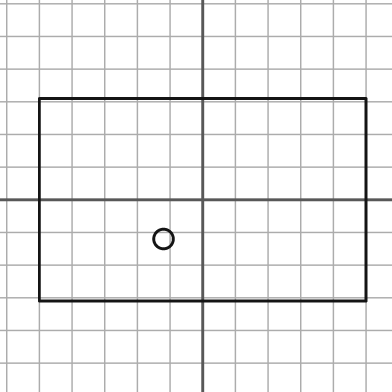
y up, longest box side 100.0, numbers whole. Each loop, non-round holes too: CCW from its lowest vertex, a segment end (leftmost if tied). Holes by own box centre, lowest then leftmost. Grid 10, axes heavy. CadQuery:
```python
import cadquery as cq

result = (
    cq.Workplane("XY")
    .moveTo(-50.0, -31.0)
    .lineTo(50.0, -31.0)
    .lineTo(50.0, 31.0)
    .lineTo(-50.0, 31.0)
    .close()
    .moveTo(-12.0, -12.0)
    .circle(3.0)
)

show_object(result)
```